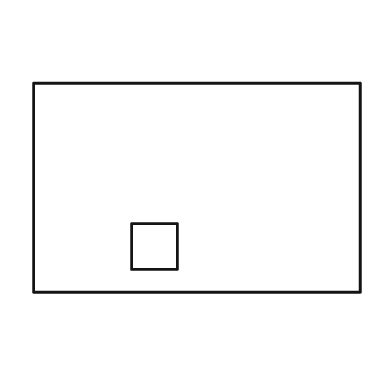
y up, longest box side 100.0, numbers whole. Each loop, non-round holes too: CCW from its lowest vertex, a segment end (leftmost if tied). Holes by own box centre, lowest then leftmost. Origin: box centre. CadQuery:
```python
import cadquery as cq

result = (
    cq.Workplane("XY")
    .moveTo(-50.0, -32.0)
    .lineTo(50.0, -32.0)
    .lineTo(50.0, 32.0)
    .lineTo(-50.0, 32.0)
    .close()
    .moveTo(-20.0, -25.0)
    .lineTo(-6.0, -25.0)
    .lineTo(-6.0, -11.0)
    .lineTo(-20.0, -11.0)
    .close()
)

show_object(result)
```